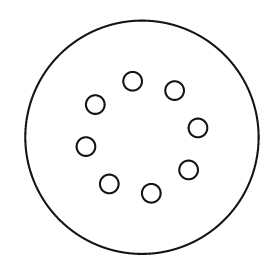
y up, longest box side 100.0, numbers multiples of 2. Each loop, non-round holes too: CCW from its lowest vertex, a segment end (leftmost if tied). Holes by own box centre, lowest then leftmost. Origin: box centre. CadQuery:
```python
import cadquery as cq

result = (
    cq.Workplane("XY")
    .moveTo(0.0, 0.0)
    .circle(50.0)
    .moveTo(4.0, -24.0)
    .circle(4.0)
    .moveTo(-14.0, -20.0)
    .circle(4.0)
    .moveTo(20.0, -14.0)
    .circle(4.0)
    .moveTo(-24.0, -4.0)
    .circle(4.0)
    .moveTo(24.0, 4.0)
    .circle(4.0)
    .moveTo(-20.0, 14.0)
    .circle(4.0)
    .moveTo(14.0, 20.0)
    .circle(4.0)
    .moveTo(-4.0, 24.0)
    .circle(4.0)
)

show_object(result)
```